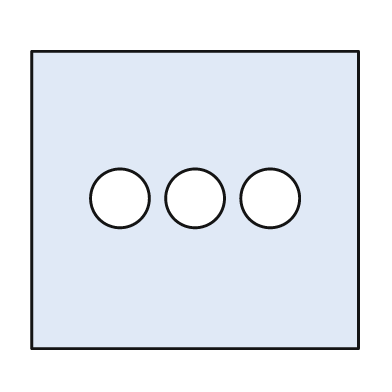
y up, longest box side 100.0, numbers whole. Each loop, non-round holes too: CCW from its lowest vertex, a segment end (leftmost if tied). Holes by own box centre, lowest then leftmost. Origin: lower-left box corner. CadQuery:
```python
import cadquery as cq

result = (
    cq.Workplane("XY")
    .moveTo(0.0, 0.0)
    .lineTo(100.0, 0.0)
    .lineTo(100.0, 91.0)
    .lineTo(0.0, 91.0)
    .close()
    .moveTo(27.0, 46.0)
    .circle(9.0)
    .moveTo(50.0, 46.0)
    .circle(9.0)
    .moveTo(73.0, 46.0)
    .circle(9.0)
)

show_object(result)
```